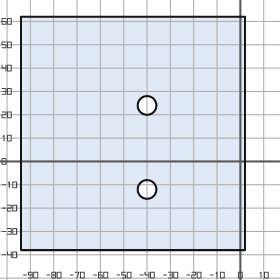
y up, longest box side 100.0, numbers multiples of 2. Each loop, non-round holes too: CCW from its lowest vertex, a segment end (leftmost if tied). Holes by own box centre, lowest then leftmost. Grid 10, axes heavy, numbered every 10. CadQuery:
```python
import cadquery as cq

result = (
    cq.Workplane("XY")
    .moveTo(-94.0, -38.0)
    .lineTo(2.0, -38.0)
    .lineTo(2.0, 62.0)
    .lineTo(-94.0, 62.0)
    .close()
    .moveTo(-40.0, -12.0)
    .circle(4.0)
    .moveTo(-40.0, 24.0)
    .circle(4.0)
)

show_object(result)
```